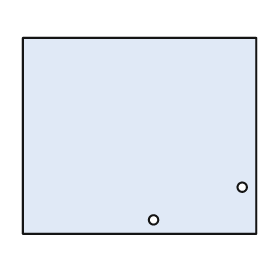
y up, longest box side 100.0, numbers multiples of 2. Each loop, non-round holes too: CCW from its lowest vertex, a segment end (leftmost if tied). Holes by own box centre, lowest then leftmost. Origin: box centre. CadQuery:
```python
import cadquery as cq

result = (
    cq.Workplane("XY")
    .moveTo(-50.0, -42.0)
    .lineTo(50.0, -42.0)
    .lineTo(50.0, 42.0)
    .lineTo(-50.0, 42.0)
    .close()
    .moveTo(6.0, -36.0)
    .circle(2.0)
    .moveTo(44.0, -22.0)
    .circle(2.0)
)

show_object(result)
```